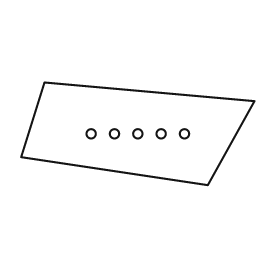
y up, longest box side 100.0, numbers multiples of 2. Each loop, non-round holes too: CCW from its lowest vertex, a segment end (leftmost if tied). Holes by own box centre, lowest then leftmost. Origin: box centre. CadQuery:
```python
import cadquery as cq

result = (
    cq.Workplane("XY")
    .moveTo(30.0, -22.0)
    .lineTo(50.0, 14.0)
    .lineTo(-40.0, 22.0)
    .lineTo(-50.0, -10.0)
    .close()
    .moveTo(-20.0, 0.0)
    .circle(2.0)
    .moveTo(-10.0, 0.0)
    .circle(2.0)
    .moveTo(0.0, 0.0)
    .circle(2.0)
    .moveTo(10.0, 0.0)
    .circle(2.0)
    .moveTo(20.0, 0.0)
    .circle(2.0)
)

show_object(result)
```